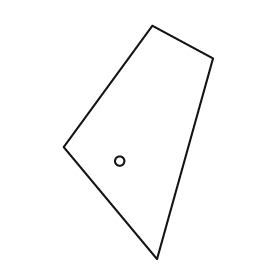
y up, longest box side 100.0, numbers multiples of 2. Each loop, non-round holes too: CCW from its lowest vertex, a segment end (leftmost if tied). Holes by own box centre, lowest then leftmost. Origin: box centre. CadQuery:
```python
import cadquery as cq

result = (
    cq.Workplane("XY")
    .moveTo(8.0, -50.0)
    .lineTo(32.0, 36.0)
    .lineTo(6.0, 50.0)
    .lineTo(-32.0, -2.0)
    .close()
    .moveTo(-8.0, -8.0)
    .circle(2.0)
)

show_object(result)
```